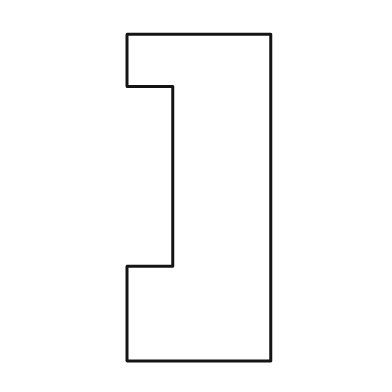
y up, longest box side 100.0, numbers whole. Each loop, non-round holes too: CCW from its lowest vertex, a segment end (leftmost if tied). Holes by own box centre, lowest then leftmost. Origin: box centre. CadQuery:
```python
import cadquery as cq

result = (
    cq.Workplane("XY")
    .moveTo(-22.0, -50.0)
    .lineTo(22.0, -50.0)
    .lineTo(22.0, 50.0)
    .lineTo(-22.0, 50.0)
    .lineTo(-22.0, 34.0)
    .lineTo(-8.0, 34.0)
    .lineTo(-8.0, -21.0)
    .lineTo(-22.0, -21.0)
    .close()
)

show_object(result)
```